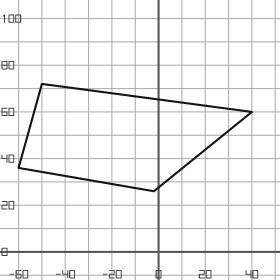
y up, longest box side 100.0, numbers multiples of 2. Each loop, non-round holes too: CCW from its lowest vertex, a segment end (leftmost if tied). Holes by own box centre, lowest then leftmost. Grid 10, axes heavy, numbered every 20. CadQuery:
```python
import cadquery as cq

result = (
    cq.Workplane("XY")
    .moveTo(-2.0, 26.0)
    .lineTo(40.0, 60.0)
    .lineTo(-50.0, 72.0)
    .lineTo(-60.0, 36.0)
    .close()
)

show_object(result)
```